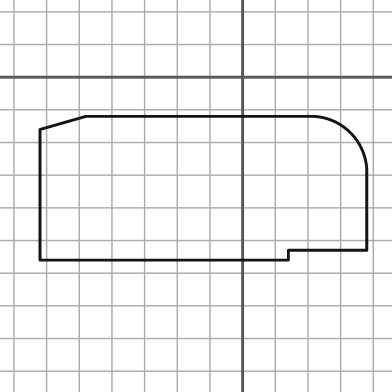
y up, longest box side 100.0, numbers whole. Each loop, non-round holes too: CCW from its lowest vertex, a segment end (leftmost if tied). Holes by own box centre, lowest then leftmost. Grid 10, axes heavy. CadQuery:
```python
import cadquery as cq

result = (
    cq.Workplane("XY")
    .moveTo(-62.0, -56.0)
    .lineTo(14.0, -56.0)
    .lineTo(14.0, -53.0)
    .lineTo(38.0, -53.0)
    .lineTo(38.0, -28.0)
    .threePointArc((33.0, -17.0), (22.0, -12.0))
    .lineTo(-48.0, -12.0)
    .lineTo(-62.0, -16.0)
    .close()
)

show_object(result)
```